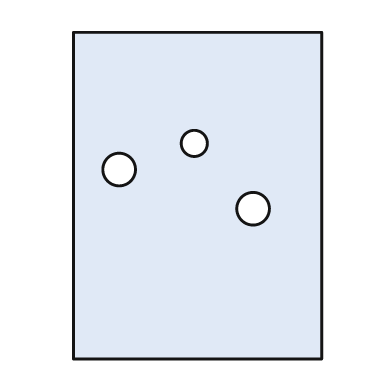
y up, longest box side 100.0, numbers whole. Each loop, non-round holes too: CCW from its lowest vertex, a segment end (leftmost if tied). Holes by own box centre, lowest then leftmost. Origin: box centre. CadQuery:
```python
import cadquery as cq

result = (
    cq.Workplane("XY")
    .moveTo(-38.0, -50.0)
    .lineTo(38.0, -50.0)
    .lineTo(38.0, 50.0)
    .lineTo(-38.0, 50.0)
    .close()
    .moveTo(17.0, -4.0)
    .circle(5.0)
    .moveTo(-24.0, 8.0)
    .circle(5.0)
    .moveTo(-1.0, 16.0)
    .circle(4.0)
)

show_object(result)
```